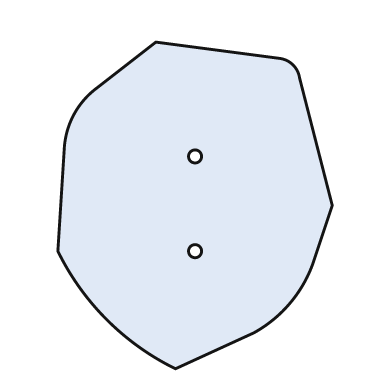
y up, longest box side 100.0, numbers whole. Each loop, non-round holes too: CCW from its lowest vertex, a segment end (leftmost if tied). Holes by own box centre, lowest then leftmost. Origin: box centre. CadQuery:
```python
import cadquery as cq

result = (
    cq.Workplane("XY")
    .moveTo(-6.0, -50.0)
    .lineTo(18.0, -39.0)
    .threePointArc((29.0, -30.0), (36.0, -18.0))
    .lineTo(42.0, 0.0)
    .lineTo(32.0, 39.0)
    .threePointArc((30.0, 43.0), (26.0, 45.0))
    .lineTo(-12.0, 50.0)
    .lineTo(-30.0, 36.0)
    .threePointArc((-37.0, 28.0), (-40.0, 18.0))
    .lineTo(-42.0, -14.0)
    .threePointArc((-27.0, -35.0), (-6.0, -50.0))
    .close()
    .moveTo(0.0, -14.0)
    .circle(2.0)
    .moveTo(0.0, 15.0)
    .circle(2.0)
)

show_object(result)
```